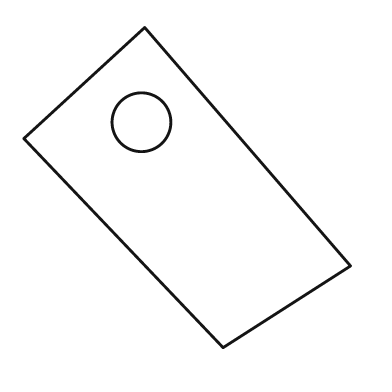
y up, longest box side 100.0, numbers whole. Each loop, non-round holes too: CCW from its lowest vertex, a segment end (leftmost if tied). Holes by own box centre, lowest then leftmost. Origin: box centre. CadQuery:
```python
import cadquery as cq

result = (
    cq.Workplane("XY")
    .moveTo(11.0, -49.0)
    .lineTo(50.0, -24.0)
    .lineTo(-13.0, 49.0)
    .lineTo(-50.0, 15.0)
    .close()
    .moveTo(-14.0, 20.0)
    .circle(9.0)
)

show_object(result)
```